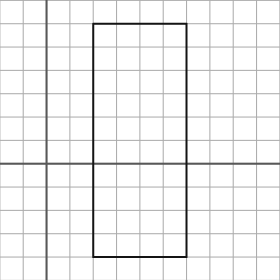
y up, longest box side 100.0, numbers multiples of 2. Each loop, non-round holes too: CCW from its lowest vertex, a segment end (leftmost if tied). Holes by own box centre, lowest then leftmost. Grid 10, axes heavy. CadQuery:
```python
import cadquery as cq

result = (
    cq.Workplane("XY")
    .moveTo(20.0, -40.0)
    .lineTo(60.0, -40.0)
    .lineTo(60.0, 60.0)
    .lineTo(20.0, 60.0)
    .close()
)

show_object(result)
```